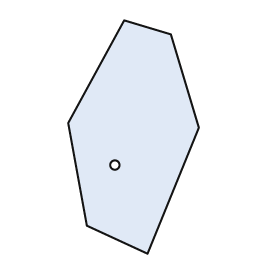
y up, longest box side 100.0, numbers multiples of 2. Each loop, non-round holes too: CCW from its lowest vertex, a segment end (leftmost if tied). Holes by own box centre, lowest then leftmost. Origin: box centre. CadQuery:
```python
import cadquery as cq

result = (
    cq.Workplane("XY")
    .moveTo(6.0, -50.0)
    .lineTo(28.0, 4.0)
    .lineTo(16.0, 44.0)
    .lineTo(-4.0, 50.0)
    .lineTo(-28.0, 6.0)
    .lineTo(-20.0, -38.0)
    .close()
    .moveTo(-8.0, -12.0)
    .circle(2.0)
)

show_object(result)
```